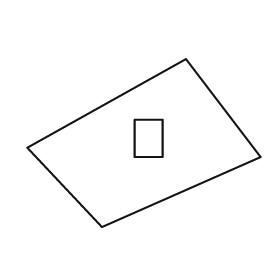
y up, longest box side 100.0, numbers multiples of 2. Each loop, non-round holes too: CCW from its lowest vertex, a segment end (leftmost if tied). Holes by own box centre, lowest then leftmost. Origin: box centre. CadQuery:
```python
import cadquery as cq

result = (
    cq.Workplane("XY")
    .moveTo(-18.0, -36.0)
    .lineTo(50.0, -6.0)
    .lineTo(18.0, 36.0)
    .lineTo(-50.0, -2.0)
    .close()
    .moveTo(-4.0, -6.0)
    .lineTo(8.0, -6.0)
    .lineTo(8.0, 10.0)
    .lineTo(-4.0, 10.0)
    .close()
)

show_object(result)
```